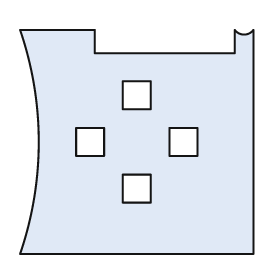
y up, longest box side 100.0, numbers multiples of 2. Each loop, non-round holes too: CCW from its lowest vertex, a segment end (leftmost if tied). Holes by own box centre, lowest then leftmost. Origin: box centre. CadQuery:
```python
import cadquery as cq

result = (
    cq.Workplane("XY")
    .moveTo(-50.0, -48.0)
    .lineTo(50.0, -48.0)
    .lineTo(50.0, 48.0)
    .threePointArc((46.0, 46.0), (42.0, 48.0))
    .lineTo(42.0, 38.0)
    .lineTo(-18.0, 38.0)
    .lineTo(-18.0, 48.0)
    .lineTo(-50.0, 48.0)
    .threePointArc((-42.0, 0.0), (-50.0, -48.0))
    .close()
    .moveTo(-6.0, -26.0)
    .lineTo(6.0, -26.0)
    .lineTo(6.0, -14.0)
    .lineTo(-6.0, -14.0)
    .close()
    .moveTo(-26.0, -6.0)
    .lineTo(-14.0, -6.0)
    .lineTo(-14.0, 6.0)
    .lineTo(-26.0, 6.0)
    .close()
    .moveTo(14.0, -6.0)
    .lineTo(26.0, -6.0)
    .lineTo(26.0, 6.0)
    .lineTo(14.0, 6.0)
    .close()
    .moveTo(-6.0, 14.0)
    .lineTo(6.0, 14.0)
    .lineTo(6.0, 26.0)
    .lineTo(-6.0, 26.0)
    .close()
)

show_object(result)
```